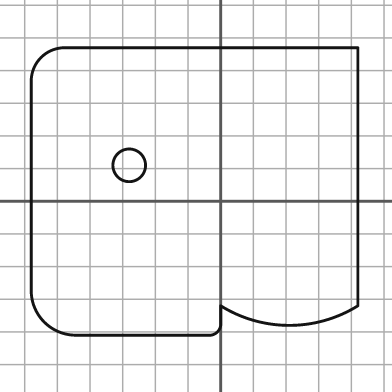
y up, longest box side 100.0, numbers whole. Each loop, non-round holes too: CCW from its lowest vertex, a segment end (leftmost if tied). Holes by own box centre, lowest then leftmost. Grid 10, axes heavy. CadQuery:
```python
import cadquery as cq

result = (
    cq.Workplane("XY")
    .moveTo(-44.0, -41.0)
    .lineTo(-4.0, -41.0)
    .threePointArc((-1.0, -40.0), (0.0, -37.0))
    .lineTo(0.0, -32.0)
    .threePointArc((21.0, -38.0), (42.0, -32.0))
    .lineTo(42.0, 47.0)
    .lineTo(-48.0, 47.0)
    .threePointArc((-55.0, 44.0), (-58.0, 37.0))
    .lineTo(-58.0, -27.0)
    .threePointArc((-54.0, -37.0), (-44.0, -41.0))
    .close()
    .moveTo(-28.0, 11.0)
    .circle(5.0)
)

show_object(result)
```